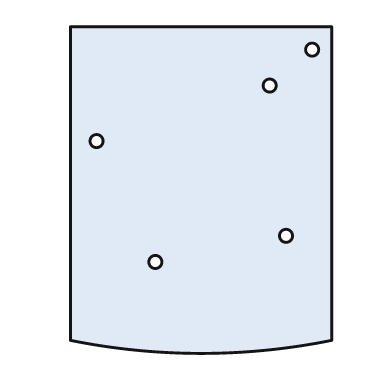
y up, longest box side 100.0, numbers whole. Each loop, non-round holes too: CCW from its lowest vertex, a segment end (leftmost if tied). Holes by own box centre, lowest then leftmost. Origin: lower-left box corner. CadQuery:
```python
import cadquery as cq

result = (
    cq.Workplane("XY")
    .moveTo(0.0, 4.0)
    .threePointArc((40.0, 0.0), (80.0, 4.0))
    .lineTo(80.0, 100.0)
    .lineTo(0.0, 100.0)
    .close()
    .moveTo(26.0, 28.0)
    .circle(2.0)
    .moveTo(66.0, 36.0)
    .circle(2.0)
    .moveTo(8.0, 65.0)
    .circle(2.0)
    .moveTo(61.0, 82.0)
    .circle(2.0)
    .moveTo(74.0, 93.0)
    .circle(2.0)
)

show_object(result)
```